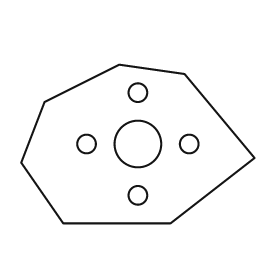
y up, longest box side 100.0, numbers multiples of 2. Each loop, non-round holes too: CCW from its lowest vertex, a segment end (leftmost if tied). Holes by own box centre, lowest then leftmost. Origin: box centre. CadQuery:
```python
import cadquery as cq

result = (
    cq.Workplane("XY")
    .moveTo(-32.0, -34.0)
    .lineTo(14.0, -34.0)
    .lineTo(50.0, -6.0)
    .lineTo(20.0, 30.0)
    .lineTo(-8.0, 34.0)
    .lineTo(-40.0, 18.0)
    .lineTo(-50.0, -8.0)
    .close()
    .moveTo(0.0, -22.0)
    .circle(4.0)
    .moveTo(-22.0, 0.0)
    .circle(4.0)
    .moveTo(0.0, 0.0)
    .circle(10.0)
    .moveTo(22.0, 0.0)
    .circle(4.0)
    .moveTo(0.0, 22.0)
    .circle(4.0)
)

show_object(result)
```